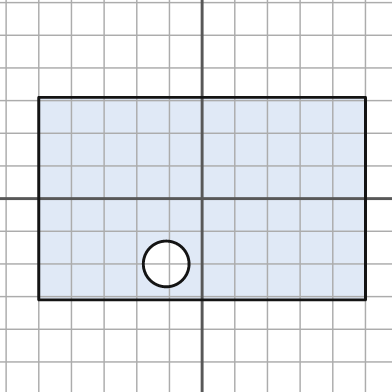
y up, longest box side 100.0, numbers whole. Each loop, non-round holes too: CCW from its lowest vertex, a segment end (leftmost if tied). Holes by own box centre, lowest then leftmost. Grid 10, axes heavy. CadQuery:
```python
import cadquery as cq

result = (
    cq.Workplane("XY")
    .moveTo(-50.0, -31.0)
    .lineTo(50.0, -31.0)
    .lineTo(50.0, 31.0)
    .lineTo(-50.0, 31.0)
    .close()
    .moveTo(-11.0, -20.0)
    .circle(7.0)
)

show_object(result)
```